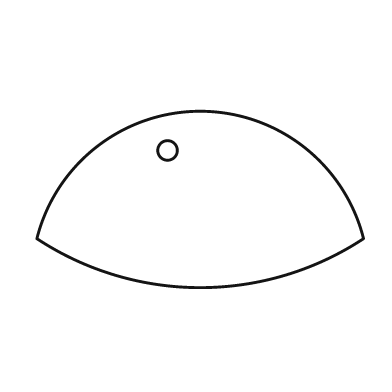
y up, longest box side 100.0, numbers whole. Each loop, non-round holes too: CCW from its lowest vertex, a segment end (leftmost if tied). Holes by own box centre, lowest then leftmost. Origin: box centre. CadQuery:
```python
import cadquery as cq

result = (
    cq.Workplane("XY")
    .moveTo(-50.0, -12.0)
    .threePointArc((0.0, -27.0), (50.0, -12.0))
    .threePointArc((0.0, 27.0), (-50.0, -12.0))
    .close()
    .moveTo(-10.0, 15.0)
    .circle(3.0)
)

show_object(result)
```